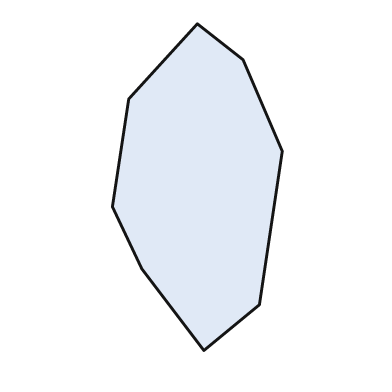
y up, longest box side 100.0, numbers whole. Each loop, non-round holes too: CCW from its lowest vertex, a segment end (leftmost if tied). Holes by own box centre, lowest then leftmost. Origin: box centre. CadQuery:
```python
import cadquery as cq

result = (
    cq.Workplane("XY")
    .moveTo(2.0, -50.0)
    .lineTo(19.0, -36.0)
    .lineTo(26.0, 11.0)
    .lineTo(14.0, 39.0)
    .lineTo(0.0, 50.0)
    .lineTo(-21.0, 27.0)
    .lineTo(-26.0, -6.0)
    .lineTo(-17.0, -25.0)
    .close()
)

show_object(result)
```